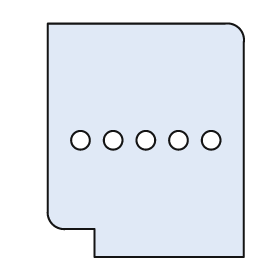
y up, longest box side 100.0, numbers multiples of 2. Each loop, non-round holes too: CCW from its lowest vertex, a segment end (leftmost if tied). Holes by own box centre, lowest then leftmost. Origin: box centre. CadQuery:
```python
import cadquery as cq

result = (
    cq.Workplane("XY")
    .moveTo(-22.0, -50.0)
    .lineTo(42.0, -50.0)
    .lineTo(42.0, 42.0)
    .threePointArc((40.0, 48.0), (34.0, 50.0))
    .lineTo(-42.0, 50.0)
    .lineTo(-42.0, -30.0)
    .threePointArc((-40.0, -36.0), (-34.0, -38.0))
    .lineTo(-22.0, -38.0)
    .close()
    .moveTo(-28.0, 0.0)
    .circle(4.0)
    .moveTo(-14.0, 0.0)
    .circle(4.0)
    .moveTo(0.0, 0.0)
    .circle(4.0)
    .moveTo(14.0, 0.0)
    .circle(4.0)
    .moveTo(28.0, 0.0)
    .circle(4.0)
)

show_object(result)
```